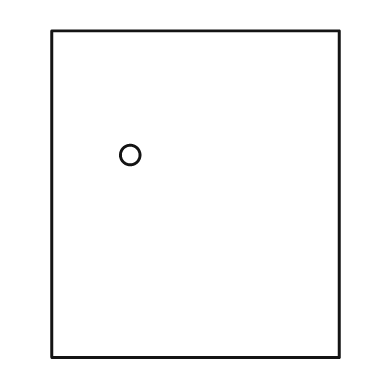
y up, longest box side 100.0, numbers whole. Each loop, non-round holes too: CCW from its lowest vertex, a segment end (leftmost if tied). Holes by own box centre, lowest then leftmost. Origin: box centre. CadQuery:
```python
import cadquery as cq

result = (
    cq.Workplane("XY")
    .moveTo(-44.0, -50.0)
    .lineTo(44.0, -50.0)
    .lineTo(44.0, 50.0)
    .lineTo(-44.0, 50.0)
    .close()
    .moveTo(-20.0, 12.0)
    .circle(3.0)
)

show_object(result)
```